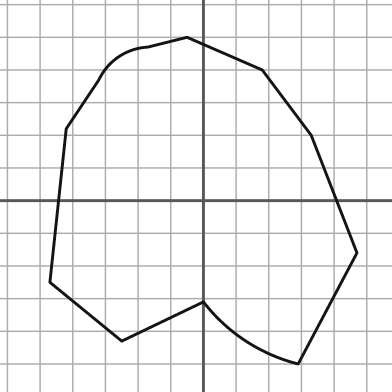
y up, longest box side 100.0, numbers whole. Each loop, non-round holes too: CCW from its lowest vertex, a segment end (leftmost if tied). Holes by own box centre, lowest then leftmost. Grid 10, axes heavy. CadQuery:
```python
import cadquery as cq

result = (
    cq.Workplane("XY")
    .moveTo(29.0, -50.0)
    .lineTo(47.0, -16.0)
    .lineTo(33.0, 20.0)
    .lineTo(18.0, 40.0)
    .lineTo(-5.0, 50.0)
    .lineTo(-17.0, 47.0)
    .threePointArc((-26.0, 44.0), (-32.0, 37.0))
    .lineTo(-42.0, 22.0)
    .lineTo(-47.0, -25.0)
    .lineTo(-25.0, -43.0)
    .lineTo(0.0, -31.0)
    .threePointArc((13.0, -43.0), (29.0, -50.0))
    .close()
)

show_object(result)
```